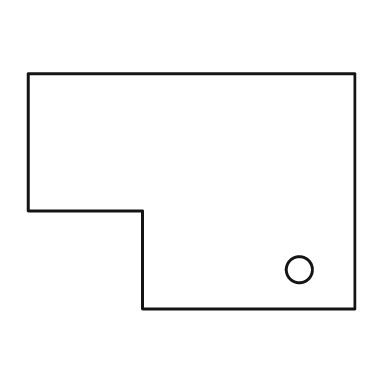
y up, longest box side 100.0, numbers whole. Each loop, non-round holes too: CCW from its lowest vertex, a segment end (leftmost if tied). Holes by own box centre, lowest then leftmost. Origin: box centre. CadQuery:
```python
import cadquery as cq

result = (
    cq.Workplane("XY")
    .moveTo(-15.0, -36.0)
    .lineTo(50.0, -36.0)
    .lineTo(50.0, 36.0)
    .lineTo(-50.0, 36.0)
    .lineTo(-50.0, -6.0)
    .lineTo(-15.0, -6.0)
    .close()
    .moveTo(33.0, -24.0)
    .circle(4.0)
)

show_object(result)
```